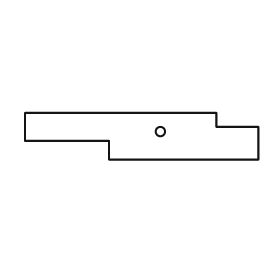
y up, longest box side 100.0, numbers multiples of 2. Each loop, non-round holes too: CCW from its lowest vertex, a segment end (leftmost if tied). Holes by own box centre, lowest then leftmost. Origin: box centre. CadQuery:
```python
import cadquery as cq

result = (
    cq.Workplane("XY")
    .moveTo(-14.0, -10.0)
    .lineTo(50.0, -10.0)
    .lineTo(50.0, 4.0)
    .lineTo(32.0, 4.0)
    .lineTo(32.0, 10.0)
    .lineTo(-50.0, 10.0)
    .lineTo(-50.0, -2.0)
    .lineTo(-14.0, -2.0)
    .close()
    .moveTo(8.0, 2.0)
    .circle(2.0)
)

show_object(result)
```